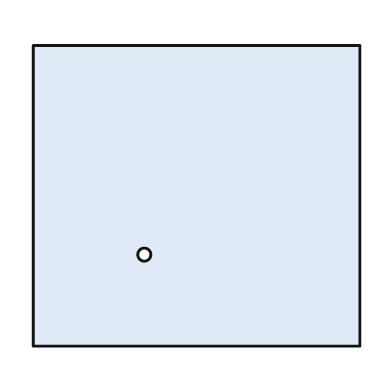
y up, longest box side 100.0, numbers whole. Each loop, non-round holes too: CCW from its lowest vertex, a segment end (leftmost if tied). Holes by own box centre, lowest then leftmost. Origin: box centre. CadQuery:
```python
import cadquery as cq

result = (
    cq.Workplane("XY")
    .moveTo(-50.0, -46.0)
    .lineTo(50.0, -46.0)
    .lineTo(50.0, 46.0)
    .lineTo(-50.0, 46.0)
    .close()
    .moveTo(-16.0, -18.0)
    .circle(2.0)
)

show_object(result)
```